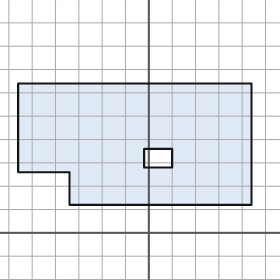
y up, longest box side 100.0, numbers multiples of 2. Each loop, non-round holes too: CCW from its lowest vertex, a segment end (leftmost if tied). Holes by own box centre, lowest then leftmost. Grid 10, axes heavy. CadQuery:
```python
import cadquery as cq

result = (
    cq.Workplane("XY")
    .moveTo(-34.0, 12.0)
    .lineTo(44.0, 12.0)
    .lineTo(44.0, 64.0)
    .lineTo(-56.0, 64.0)
    .lineTo(-56.0, 26.0)
    .lineTo(-34.0, 26.0)
    .close()
    .moveTo(-2.0, 28.0)
    .lineTo(10.0, 28.0)
    .lineTo(10.0, 36.0)
    .lineTo(-2.0, 36.0)
    .close()
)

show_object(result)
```